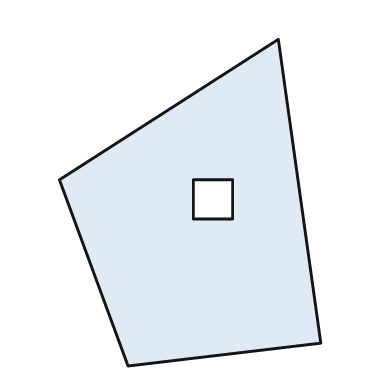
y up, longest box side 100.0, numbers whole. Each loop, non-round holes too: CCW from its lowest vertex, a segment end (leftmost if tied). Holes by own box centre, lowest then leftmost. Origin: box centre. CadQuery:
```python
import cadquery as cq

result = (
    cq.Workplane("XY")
    .moveTo(-19.0, -50.0)
    .lineTo(40.0, -43.0)
    .lineTo(27.0, 50.0)
    .lineTo(-40.0, 7.0)
    .close()
    .moveTo(1.0, -5.0)
    .lineTo(13.0, -5.0)
    .lineTo(13.0, 7.0)
    .lineTo(1.0, 7.0)
    .close()
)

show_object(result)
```